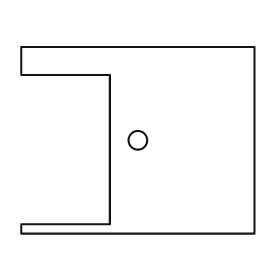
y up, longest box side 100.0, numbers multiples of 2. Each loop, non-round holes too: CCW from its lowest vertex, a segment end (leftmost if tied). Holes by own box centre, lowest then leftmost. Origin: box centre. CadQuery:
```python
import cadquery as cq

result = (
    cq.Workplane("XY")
    .moveTo(-50.0, -40.0)
    .lineTo(50.0, -40.0)
    .lineTo(50.0, 40.0)
    .lineTo(-50.0, 40.0)
    .lineTo(-50.0, 28.0)
    .lineTo(-12.0, 28.0)
    .lineTo(-12.0, -36.0)
    .lineTo(-50.0, -36.0)
    .close()
    .moveTo(0.0, 0.0)
    .circle(4.0)
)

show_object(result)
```